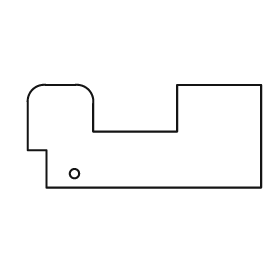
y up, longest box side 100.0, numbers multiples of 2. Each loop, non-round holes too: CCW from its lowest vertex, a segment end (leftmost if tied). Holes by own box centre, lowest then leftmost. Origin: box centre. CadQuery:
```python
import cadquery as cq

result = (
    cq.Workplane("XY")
    .moveTo(-42.0, -22.0)
    .lineTo(50.0, -22.0)
    .lineTo(50.0, 22.0)
    .lineTo(14.0, 22.0)
    .lineTo(14.0, 2.0)
    .lineTo(-22.0, 2.0)
    .lineTo(-22.0, 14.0)
    .threePointArc((-24.0, 20.0), (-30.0, 22.0))
    .lineTo(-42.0, 22.0)
    .threePointArc((-48.0, 20.0), (-50.0, 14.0))
    .lineTo(-50.0, -6.0)
    .lineTo(-42.0, -6.0)
    .close()
    .moveTo(-30.0, -16.0)
    .circle(2.0)
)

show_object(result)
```